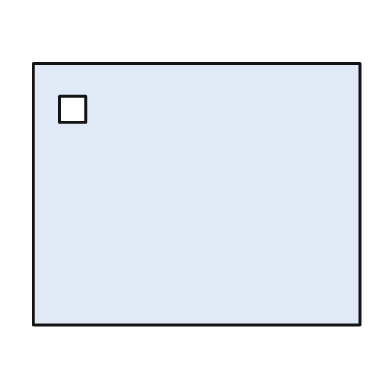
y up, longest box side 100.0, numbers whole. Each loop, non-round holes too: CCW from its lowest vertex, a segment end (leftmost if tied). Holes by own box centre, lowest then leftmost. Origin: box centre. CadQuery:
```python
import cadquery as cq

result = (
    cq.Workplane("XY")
    .moveTo(-50.0, -40.0)
    .lineTo(50.0, -40.0)
    .lineTo(50.0, 40.0)
    .lineTo(-50.0, 40.0)
    .close()
    .moveTo(-42.0, 22.0)
    .lineTo(-34.0, 22.0)
    .lineTo(-34.0, 30.0)
    .lineTo(-42.0, 30.0)
    .close()
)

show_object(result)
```